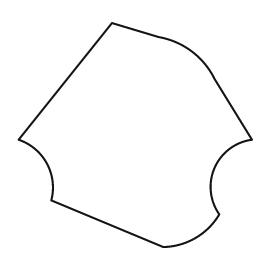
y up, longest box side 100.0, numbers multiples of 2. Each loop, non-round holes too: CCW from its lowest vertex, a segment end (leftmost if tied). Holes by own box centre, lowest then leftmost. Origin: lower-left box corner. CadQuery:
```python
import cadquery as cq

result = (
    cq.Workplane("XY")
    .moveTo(62.0, 0.0)
    .threePointArc((76.0, 4.0), (86.0, 14.0))
    .threePointArc((84.0, 34.0), (100.0, 46.0))
    .lineTo(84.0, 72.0)
    .threePointArc((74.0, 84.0), (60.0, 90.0))
    .lineTo(40.0, 96.0)
    .lineTo(0.0, 46.0)
    .threePointArc((12.0, 36.0), (14.0, 20.0))
    .close()
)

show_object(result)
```